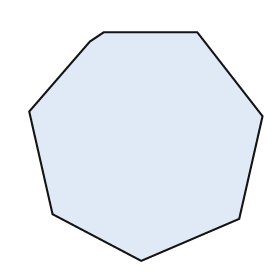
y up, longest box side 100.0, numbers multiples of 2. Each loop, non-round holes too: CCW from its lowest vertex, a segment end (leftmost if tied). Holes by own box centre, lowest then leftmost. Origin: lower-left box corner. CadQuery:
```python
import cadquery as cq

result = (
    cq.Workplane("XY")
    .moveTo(48.0, 0.0)
    .lineTo(90.0, 18.0)
    .lineTo(100.0, 62.0)
    .lineTo(72.0, 98.0)
    .lineTo(32.0, 98.0)
    .lineTo(26.0, 94.0)
    .lineTo(0.0, 64.0)
    .lineTo(10.0, 20.0)
    .close()
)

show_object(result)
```